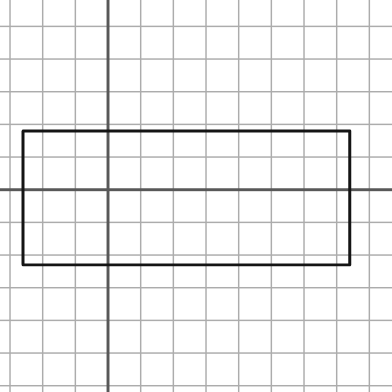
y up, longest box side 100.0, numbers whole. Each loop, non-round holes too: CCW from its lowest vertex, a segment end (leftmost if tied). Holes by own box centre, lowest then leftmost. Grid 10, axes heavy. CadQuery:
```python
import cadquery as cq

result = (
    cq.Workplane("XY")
    .moveTo(-26.0, -23.0)
    .lineTo(74.0, -23.0)
    .lineTo(74.0, 18.0)
    .lineTo(-26.0, 18.0)
    .close()
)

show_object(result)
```